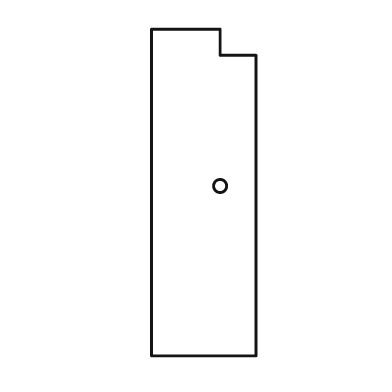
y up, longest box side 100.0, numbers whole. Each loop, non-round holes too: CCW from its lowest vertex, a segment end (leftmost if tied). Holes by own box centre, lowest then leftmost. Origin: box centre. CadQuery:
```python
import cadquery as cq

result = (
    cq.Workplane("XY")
    .moveTo(-16.0, -50.0)
    .lineTo(16.0, -50.0)
    .lineTo(16.0, 42.0)
    .lineTo(5.0, 42.0)
    .lineTo(5.0, 50.0)
    .lineTo(-16.0, 50.0)
    .close()
    .moveTo(5.0, 2.0)
    .circle(2.0)
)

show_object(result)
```